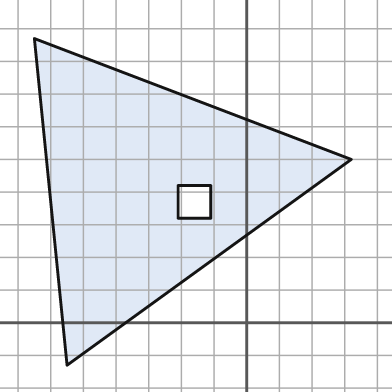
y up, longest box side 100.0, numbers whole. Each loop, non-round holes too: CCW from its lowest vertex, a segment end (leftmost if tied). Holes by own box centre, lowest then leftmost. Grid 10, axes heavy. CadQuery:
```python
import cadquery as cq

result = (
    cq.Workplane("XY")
    .moveTo(-55.0, -13.0)
    .lineTo(32.0, 50.0)
    .lineTo(-65.0, 87.0)
    .close()
    .moveTo(-21.0, 32.0)
    .lineTo(-11.0, 32.0)
    .lineTo(-11.0, 42.0)
    .lineTo(-21.0, 42.0)
    .close()
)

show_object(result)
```